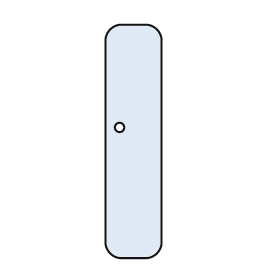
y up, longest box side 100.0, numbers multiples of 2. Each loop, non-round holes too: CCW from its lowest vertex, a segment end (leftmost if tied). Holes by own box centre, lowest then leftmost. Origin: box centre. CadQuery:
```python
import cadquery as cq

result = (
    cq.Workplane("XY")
    .moveTo(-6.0, -50.0)
    .lineTo(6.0, -50.0)
    .threePointArc((10.0, -48.0), (12.0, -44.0))
    .lineTo(12.0, 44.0)
    .threePointArc((10.0, 48.0), (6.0, 50.0))
    .lineTo(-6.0, 50.0)
    .threePointArc((-10.0, 48.0), (-12.0, 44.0))
    .lineTo(-12.0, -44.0)
    .threePointArc((-10.0, -48.0), (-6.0, -50.0))
    .close()
    .moveTo(-6.0, 6.0)
    .circle(2.0)
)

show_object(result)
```